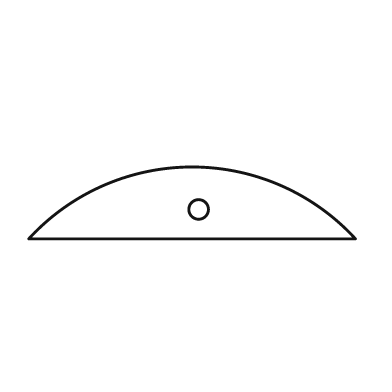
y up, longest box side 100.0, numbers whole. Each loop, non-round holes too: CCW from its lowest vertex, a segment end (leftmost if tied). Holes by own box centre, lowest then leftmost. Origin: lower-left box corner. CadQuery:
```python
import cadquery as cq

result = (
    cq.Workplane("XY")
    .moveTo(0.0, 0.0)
    .lineTo(100.0, 0.0)
    .threePointArc((50.0, 22.0), (0.0, 0.0))
    .close()
    .moveTo(52.0, 9.0)
    .circle(3.0)
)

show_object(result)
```